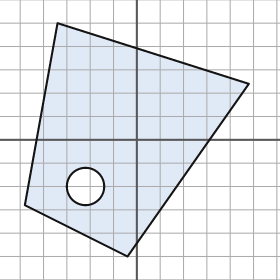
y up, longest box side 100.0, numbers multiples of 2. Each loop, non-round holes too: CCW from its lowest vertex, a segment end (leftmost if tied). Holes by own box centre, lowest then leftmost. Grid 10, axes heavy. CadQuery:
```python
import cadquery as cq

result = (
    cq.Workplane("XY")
    .moveTo(-4.0, -50.0)
    .lineTo(48.0, 24.0)
    .lineTo(-34.0, 50.0)
    .lineTo(-48.0, -28.0)
    .close()
    .moveTo(-22.0, -20.0)
    .circle(8.0)
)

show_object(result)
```